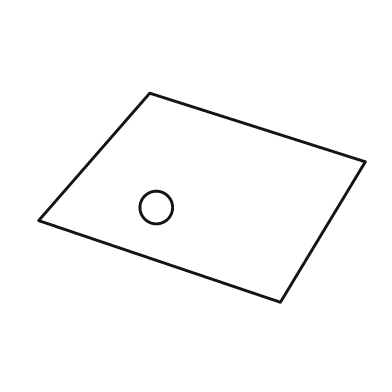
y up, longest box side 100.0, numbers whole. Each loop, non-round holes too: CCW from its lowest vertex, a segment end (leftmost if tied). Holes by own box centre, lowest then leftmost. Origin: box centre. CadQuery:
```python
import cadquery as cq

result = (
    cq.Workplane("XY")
    .moveTo(24.0, -32.0)
    .lineTo(50.0, 11.0)
    .lineTo(-16.0, 32.0)
    .lineTo(-50.0, -7.0)
    .close()
    .moveTo(-14.0, -3.0)
    .circle(5.0)
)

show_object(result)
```